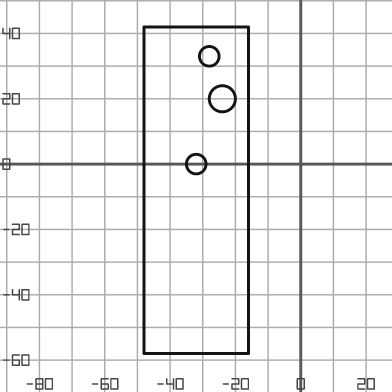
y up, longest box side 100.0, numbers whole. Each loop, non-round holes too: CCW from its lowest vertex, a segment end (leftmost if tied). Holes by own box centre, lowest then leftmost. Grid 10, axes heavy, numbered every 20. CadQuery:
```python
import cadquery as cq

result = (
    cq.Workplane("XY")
    .moveTo(-48.0, -58.0)
    .lineTo(-16.0, -58.0)
    .lineTo(-16.0, 42.0)
    .lineTo(-48.0, 42.0)
    .close()
    .moveTo(-32.0, 0.0)
    .circle(3.0)
    .moveTo(-24.0, 20.0)
    .circle(4.0)
    .moveTo(-28.0, 33.0)
    .circle(3.0)
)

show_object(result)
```